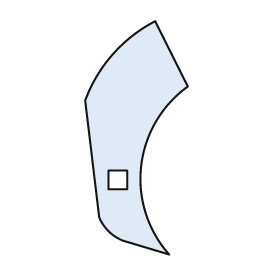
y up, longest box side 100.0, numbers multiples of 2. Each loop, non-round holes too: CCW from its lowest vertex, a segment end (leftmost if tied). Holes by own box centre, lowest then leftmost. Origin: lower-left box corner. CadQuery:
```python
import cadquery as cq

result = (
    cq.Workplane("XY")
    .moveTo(36.0, 0.0)
    .threePointArc((24.0, 38.0), (44.0, 72.0))
    .lineTo(30.0, 100.0)
    .threePointArc((12.0, 86.0), (0.0, 66.0))
    .lineTo(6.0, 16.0)
    .threePointArc((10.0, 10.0), (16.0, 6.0))
    .close()
    .moveTo(10.0, 28.0)
    .lineTo(18.0, 28.0)
    .lineTo(18.0, 36.0)
    .lineTo(10.0, 36.0)
    .close()
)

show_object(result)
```